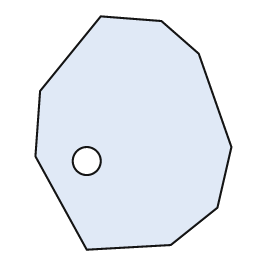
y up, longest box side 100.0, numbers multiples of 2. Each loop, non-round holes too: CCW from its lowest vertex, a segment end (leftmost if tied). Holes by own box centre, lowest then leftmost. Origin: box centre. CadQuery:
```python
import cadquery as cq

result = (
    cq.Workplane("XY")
    .moveTo(-20.0, -50.0)
    .lineTo(16.0, -48.0)
    .lineTo(36.0, -32.0)
    .lineTo(42.0, -6.0)
    .lineTo(28.0, 34.0)
    .lineTo(12.0, 48.0)
    .lineTo(-14.0, 50.0)
    .lineTo(-40.0, 18.0)
    .lineTo(-42.0, -10.0)
    .close()
    .moveTo(-20.0, -12.0)
    .circle(6.0)
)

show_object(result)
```